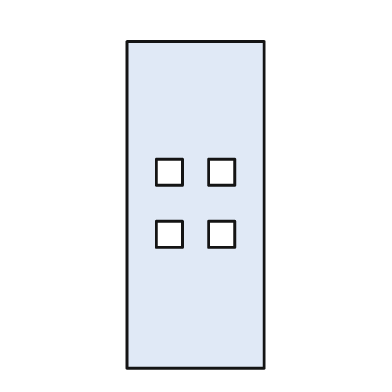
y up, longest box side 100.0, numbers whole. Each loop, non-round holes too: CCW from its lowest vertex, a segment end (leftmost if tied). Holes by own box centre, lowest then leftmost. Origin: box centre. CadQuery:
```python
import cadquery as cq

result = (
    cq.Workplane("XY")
    .moveTo(-21.0, -50.0)
    .lineTo(21.0, -50.0)
    .lineTo(21.0, 50.0)
    .lineTo(-21.0, 50.0)
    .close()
    .moveTo(-12.0, -13.0)
    .lineTo(-4.0, -13.0)
    .lineTo(-4.0, -5.0)
    .lineTo(-12.0, -5.0)
    .close()
    .moveTo(4.0, -13.0)
    .lineTo(12.0, -13.0)
    .lineTo(12.0, -5.0)
    .lineTo(4.0, -5.0)
    .close()
    .moveTo(-12.0, 6.0)
    .lineTo(-4.0, 6.0)
    .lineTo(-4.0, 14.0)
    .lineTo(-12.0, 14.0)
    .close()
    .moveTo(4.0, 6.0)
    .lineTo(12.0, 6.0)
    .lineTo(12.0, 14.0)
    .lineTo(4.0, 14.0)
    .close()
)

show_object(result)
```